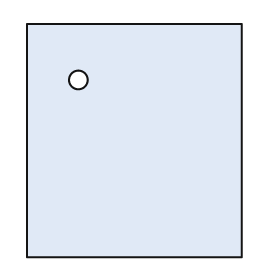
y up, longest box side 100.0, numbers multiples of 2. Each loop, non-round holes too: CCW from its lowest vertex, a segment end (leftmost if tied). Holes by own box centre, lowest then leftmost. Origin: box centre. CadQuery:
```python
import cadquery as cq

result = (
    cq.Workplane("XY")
    .moveTo(-46.0, -50.0)
    .lineTo(46.0, -50.0)
    .lineTo(46.0, 50.0)
    .lineTo(-46.0, 50.0)
    .close()
    .moveTo(-24.0, 26.0)
    .circle(4.0)
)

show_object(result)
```